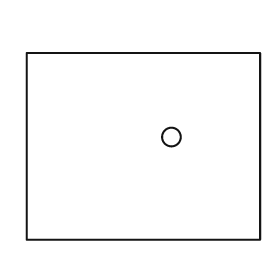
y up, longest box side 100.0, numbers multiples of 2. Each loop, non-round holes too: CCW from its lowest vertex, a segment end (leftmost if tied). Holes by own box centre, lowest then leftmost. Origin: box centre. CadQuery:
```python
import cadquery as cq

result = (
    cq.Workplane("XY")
    .moveTo(-50.0, -40.0)
    .lineTo(50.0, -40.0)
    .lineTo(50.0, 40.0)
    .lineTo(-50.0, 40.0)
    .close()
    .moveTo(12.0, 4.0)
    .circle(4.0)
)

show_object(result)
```